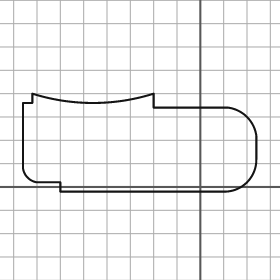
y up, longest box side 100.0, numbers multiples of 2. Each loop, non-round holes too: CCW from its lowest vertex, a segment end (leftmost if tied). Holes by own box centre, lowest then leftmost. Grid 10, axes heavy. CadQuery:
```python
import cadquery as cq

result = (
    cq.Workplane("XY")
    .moveTo(-60.0, -2.0)
    .lineTo(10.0, -2.0)
    .threePointArc((20.0, 2.0), (24.0, 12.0))
    .lineTo(24.0, 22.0)
    .threePointArc((20.0, 30.0), (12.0, 34.0))
    .lineTo(-20.0, 34.0)
    .lineTo(-20.0, 40.0)
    .threePointArc((-46.0, 36.0), (-72.0, 40.0))
    .lineTo(-72.0, 36.0)
    .lineTo(-76.0, 36.0)
    .lineTo(-76.0, 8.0)
    .threePointArc((-74.0, 4.0), (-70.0, 2.0))
    .lineTo(-60.0, 2.0)
    .close()
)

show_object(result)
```